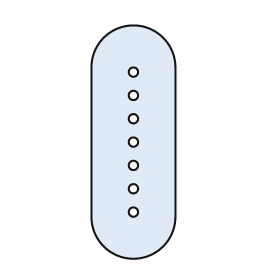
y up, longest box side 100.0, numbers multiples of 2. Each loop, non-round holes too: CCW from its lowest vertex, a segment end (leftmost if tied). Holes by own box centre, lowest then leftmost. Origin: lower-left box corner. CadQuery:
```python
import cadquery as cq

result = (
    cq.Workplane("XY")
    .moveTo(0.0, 18.0)
    .threePointArc((18.0, 0.0), (36.0, 18.0))
    .lineTo(36.0, 82.0)
    .threePointArc((18.0, 100.0), (0.0, 82.0))
    .close()
    .moveTo(18.0, 20.0)
    .circle(2.0)
    .moveTo(18.0, 30.0)
    .circle(2.0)
    .moveTo(18.0, 40.0)
    .circle(2.0)
    .moveTo(18.0, 50.0)
    .circle(2.0)
    .moveTo(18.0, 60.0)
    .circle(2.0)
    .moveTo(18.0, 70.0)
    .circle(2.0)
    .moveTo(18.0, 80.0)
    .circle(2.0)
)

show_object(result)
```